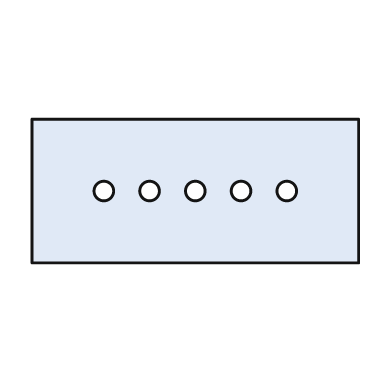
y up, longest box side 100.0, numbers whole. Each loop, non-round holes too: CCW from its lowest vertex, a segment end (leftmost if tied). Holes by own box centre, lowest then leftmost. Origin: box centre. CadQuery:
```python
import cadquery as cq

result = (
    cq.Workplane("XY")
    .moveTo(-50.0, -22.0)
    .lineTo(50.0, -22.0)
    .lineTo(50.0, 22.0)
    .lineTo(-50.0, 22.0)
    .close()
    .moveTo(-28.0, 0.0)
    .circle(3.0)
    .moveTo(-14.0, 0.0)
    .circle(3.0)
    .moveTo(0.0, 0.0)
    .circle(3.0)
    .moveTo(14.0, 0.0)
    .circle(3.0)
    .moveTo(28.0, 0.0)
    .circle(3.0)
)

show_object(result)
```